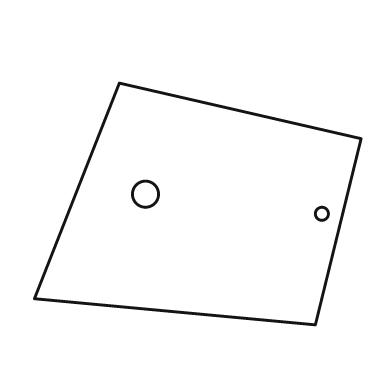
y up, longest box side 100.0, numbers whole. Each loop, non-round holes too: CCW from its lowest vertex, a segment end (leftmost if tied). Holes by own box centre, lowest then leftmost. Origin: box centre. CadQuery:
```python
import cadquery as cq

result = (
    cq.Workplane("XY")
    .moveTo(36.0, -37.0)
    .lineTo(50.0, 20.0)
    .lineTo(-24.0, 37.0)
    .lineTo(-50.0, -29.0)
    .close()
    .moveTo(38.0, -3.0)
    .circle(2.0)
    .moveTo(-16.0, 3.0)
    .circle(4.0)
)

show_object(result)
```